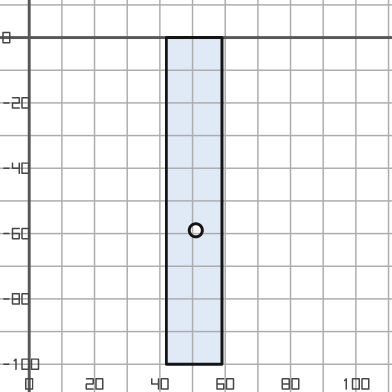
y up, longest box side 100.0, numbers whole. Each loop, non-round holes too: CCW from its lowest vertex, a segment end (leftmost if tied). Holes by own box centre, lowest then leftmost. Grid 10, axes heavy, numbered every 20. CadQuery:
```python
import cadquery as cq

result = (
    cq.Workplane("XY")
    .moveTo(42.0, -100.0)
    .lineTo(59.0, -100.0)
    .lineTo(59.0, 0.0)
    .lineTo(42.0, 0.0)
    .close()
    .moveTo(51.0, -59.0)
    .circle(2.0)
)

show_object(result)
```